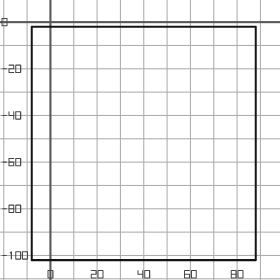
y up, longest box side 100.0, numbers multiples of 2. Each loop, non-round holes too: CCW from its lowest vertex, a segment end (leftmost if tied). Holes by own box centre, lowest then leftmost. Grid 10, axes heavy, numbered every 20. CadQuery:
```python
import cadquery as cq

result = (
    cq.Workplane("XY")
    .moveTo(-8.0, -102.0)
    .lineTo(88.0, -102.0)
    .lineTo(88.0, -2.0)
    .lineTo(-8.0, -2.0)
    .close()
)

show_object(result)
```